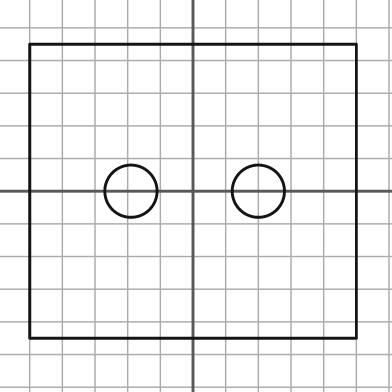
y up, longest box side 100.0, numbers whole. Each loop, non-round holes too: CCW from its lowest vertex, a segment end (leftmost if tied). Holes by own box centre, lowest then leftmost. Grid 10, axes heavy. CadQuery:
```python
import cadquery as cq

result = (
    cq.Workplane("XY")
    .moveTo(-50.0, -45.0)
    .lineTo(50.0, -45.0)
    .lineTo(50.0, 45.0)
    .lineTo(-50.0, 45.0)
    .close()
    .moveTo(-19.0, 0.0)
    .circle(8.0)
    .moveTo(20.0, 0.0)
    .circle(8.0)
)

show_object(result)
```